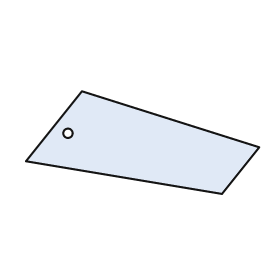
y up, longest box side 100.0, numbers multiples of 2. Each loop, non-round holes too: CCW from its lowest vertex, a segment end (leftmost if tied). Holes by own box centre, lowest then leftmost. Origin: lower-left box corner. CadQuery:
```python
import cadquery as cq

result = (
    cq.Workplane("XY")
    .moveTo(84.0, 0.0)
    .lineTo(100.0, 20.0)
    .lineTo(24.0, 44.0)
    .lineTo(0.0, 14.0)
    .close()
    .moveTo(18.0, 26.0)
    .circle(2.0)
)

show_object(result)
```